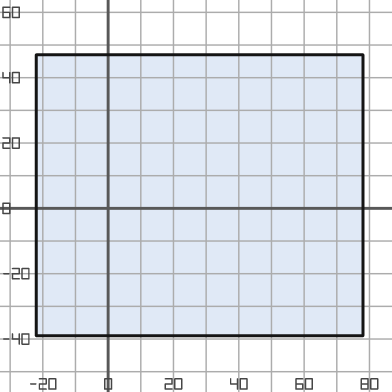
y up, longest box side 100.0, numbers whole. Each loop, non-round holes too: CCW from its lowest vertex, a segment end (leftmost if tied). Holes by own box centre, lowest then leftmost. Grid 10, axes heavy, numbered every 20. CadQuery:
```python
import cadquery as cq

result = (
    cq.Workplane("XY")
    .moveTo(-22.0, -39.0)
    .lineTo(78.0, -39.0)
    .lineTo(78.0, 47.0)
    .lineTo(-22.0, 47.0)
    .close()
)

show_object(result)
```